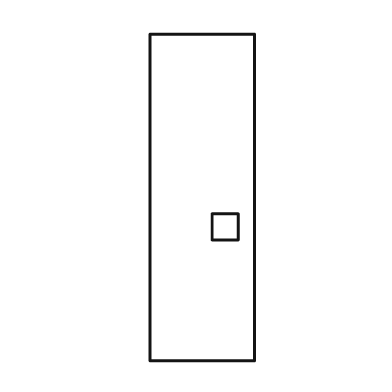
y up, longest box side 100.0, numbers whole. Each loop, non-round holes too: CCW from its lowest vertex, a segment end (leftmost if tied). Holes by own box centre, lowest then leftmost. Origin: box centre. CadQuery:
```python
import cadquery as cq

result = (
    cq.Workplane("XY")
    .moveTo(-16.0, -50.0)
    .lineTo(16.0, -50.0)
    .lineTo(16.0, 50.0)
    .lineTo(-16.0, 50.0)
    .close()
    .moveTo(3.0, -13.0)
    .lineTo(11.0, -13.0)
    .lineTo(11.0, -5.0)
    .lineTo(3.0, -5.0)
    .close()
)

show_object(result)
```